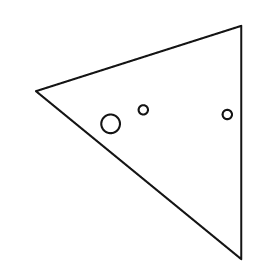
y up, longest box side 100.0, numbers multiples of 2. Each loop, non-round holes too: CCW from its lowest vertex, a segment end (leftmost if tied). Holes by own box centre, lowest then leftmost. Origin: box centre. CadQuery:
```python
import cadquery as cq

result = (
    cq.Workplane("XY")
    .moveTo(44.0, -50.0)
    .lineTo(44.0, 50.0)
    .lineTo(-44.0, 22.0)
    .close()
    .moveTo(-12.0, 8.0)
    .circle(4.0)
    .moveTo(38.0, 12.0)
    .circle(2.0)
    .moveTo(2.0, 14.0)
    .circle(2.0)
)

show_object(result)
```